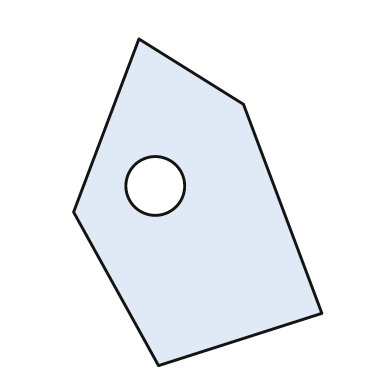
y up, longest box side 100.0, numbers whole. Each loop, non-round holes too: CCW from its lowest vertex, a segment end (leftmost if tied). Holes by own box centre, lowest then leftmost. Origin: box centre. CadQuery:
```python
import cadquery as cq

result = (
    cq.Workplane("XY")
    .moveTo(-12.0, -50.0)
    .lineTo(38.0, -34.0)
    .lineTo(14.0, 30.0)
    .lineTo(-18.0, 50.0)
    .lineTo(-38.0, -3.0)
    .close()
    .moveTo(-13.0, 5.0)
    .circle(9.0)
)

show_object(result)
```